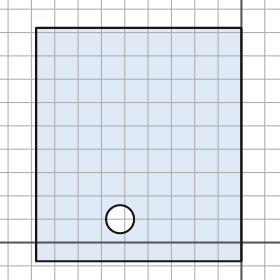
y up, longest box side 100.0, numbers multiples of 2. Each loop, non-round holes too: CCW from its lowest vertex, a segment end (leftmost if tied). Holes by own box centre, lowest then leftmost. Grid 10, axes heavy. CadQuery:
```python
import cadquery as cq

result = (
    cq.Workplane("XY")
    .moveTo(-88.0, -8.0)
    .lineTo(0.0, -8.0)
    .lineTo(0.0, 92.0)
    .lineTo(-88.0, 92.0)
    .close()
    .moveTo(-52.0, 10.0)
    .circle(6.0)
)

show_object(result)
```